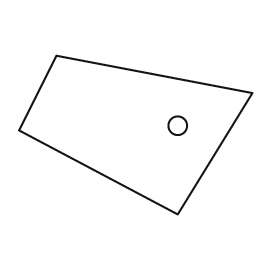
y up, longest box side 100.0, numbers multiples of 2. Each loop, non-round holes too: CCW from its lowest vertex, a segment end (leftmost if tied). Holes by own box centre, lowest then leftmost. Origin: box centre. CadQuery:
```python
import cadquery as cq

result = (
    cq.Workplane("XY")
    .moveTo(18.0, -34.0)
    .lineTo(50.0, 18.0)
    .lineTo(-34.0, 34.0)
    .lineTo(-50.0, 2.0)
    .close()
    .moveTo(18.0, 4.0)
    .circle(4.0)
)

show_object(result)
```